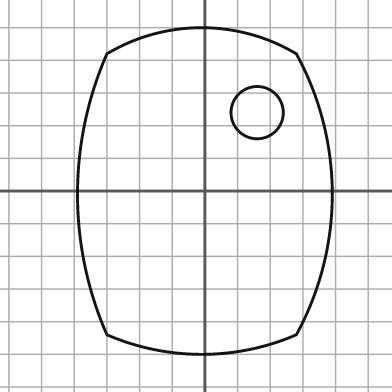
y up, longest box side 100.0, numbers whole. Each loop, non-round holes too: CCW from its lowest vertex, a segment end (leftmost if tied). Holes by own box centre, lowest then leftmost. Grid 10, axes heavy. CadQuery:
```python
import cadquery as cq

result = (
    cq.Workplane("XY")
    .moveTo(-30.0, -44.0)
    .threePointArc((-1.0, -50.0), (28.0, -44.0))
    .threePointArc((39.0, -1.0), (28.0, 42.0))
    .threePointArc((-1.0, 50.0), (-30.0, 42.0))
    .threePointArc((-39.0, -1.0), (-30.0, -44.0))
    .close()
    .moveTo(16.0, 24.0)
    .circle(8.0)
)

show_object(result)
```